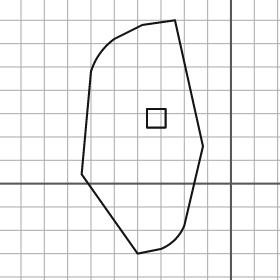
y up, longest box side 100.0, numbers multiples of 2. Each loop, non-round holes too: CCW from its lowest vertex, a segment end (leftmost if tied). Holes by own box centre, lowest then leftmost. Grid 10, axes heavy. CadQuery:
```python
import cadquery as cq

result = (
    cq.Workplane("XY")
    .moveTo(-40.0, -30.0)
    .lineTo(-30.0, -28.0)
    .threePointArc((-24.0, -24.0), (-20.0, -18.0))
    .lineTo(-12.0, 16.0)
    .lineTo(-24.0, 70.0)
    .lineTo(-38.0, 68.0)
    .lineTo(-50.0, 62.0)
    .threePointArc((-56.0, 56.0), (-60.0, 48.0))
    .lineTo(-64.0, 4.0)
    .close()
    .moveTo(-36.0, 24.0)
    .lineTo(-28.0, 24.0)
    .lineTo(-28.0, 32.0)
    .lineTo(-36.0, 32.0)
    .close()
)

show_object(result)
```